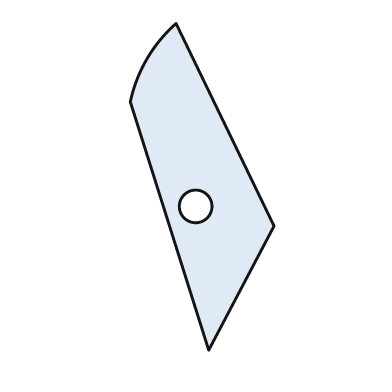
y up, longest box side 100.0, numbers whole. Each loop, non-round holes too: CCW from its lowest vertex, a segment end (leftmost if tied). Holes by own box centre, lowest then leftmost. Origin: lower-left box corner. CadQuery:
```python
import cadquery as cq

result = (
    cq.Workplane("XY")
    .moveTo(24.0, 0.0)
    .lineTo(44.0, 38.0)
    .lineTo(14.0, 100.0)
    .threePointArc((5.0, 89.0), (0.0, 76.0))
    .close()
    .moveTo(20.0, 44.0)
    .circle(5.0)
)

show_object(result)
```